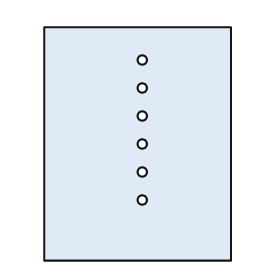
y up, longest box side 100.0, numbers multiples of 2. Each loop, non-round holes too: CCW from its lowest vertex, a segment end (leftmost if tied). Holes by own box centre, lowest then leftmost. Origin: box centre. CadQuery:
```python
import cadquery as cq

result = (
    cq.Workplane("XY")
    .moveTo(-40.0, -50.0)
    .lineTo(40.0, -50.0)
    .lineTo(40.0, 50.0)
    .lineTo(-40.0, 50.0)
    .close()
    .moveTo(2.0, -24.0)
    .circle(2.0)
    .moveTo(2.0, -12.0)
    .circle(2.0)
    .moveTo(2.0, 0.0)
    .circle(2.0)
    .moveTo(2.0, 12.0)
    .circle(2.0)
    .moveTo(2.0, 24.0)
    .circle(2.0)
    .moveTo(2.0, 36.0)
    .circle(2.0)
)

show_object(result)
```